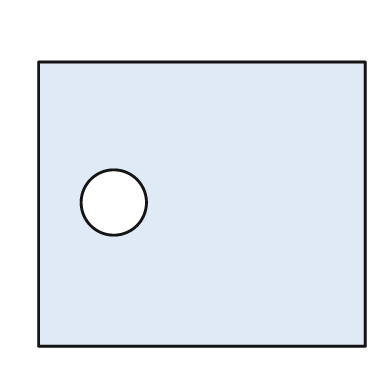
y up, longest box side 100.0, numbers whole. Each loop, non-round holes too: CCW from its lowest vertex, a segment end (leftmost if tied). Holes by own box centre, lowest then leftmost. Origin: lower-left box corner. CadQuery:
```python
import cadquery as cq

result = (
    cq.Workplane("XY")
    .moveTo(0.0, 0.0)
    .lineTo(100.0, 0.0)
    .lineTo(100.0, 87.0)
    .lineTo(0.0, 87.0)
    .close()
    .moveTo(23.0, 44.0)
    .circle(10.0)
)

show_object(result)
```